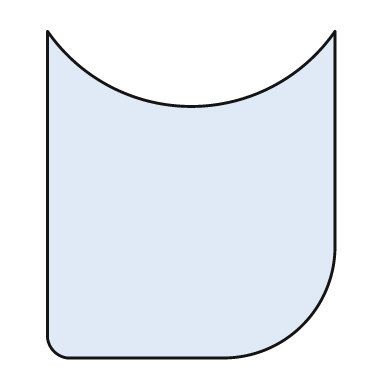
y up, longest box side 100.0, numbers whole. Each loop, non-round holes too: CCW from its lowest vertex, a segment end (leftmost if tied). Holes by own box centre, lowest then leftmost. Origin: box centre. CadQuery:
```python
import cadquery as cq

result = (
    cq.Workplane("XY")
    .moveTo(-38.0, -50.0)
    .lineTo(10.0, -50.0)
    .threePointArc((34.0, -40.0), (44.0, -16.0))
    .lineTo(44.0, 50.0)
    .threePointArc((0.0, 27.0), (-44.0, 50.0))
    .lineTo(-44.0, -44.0)
    .threePointArc((-42.0, -48.0), (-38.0, -50.0))
    .close()
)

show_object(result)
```